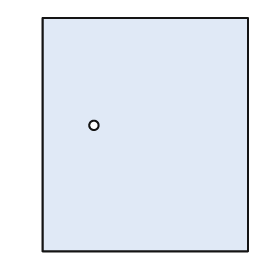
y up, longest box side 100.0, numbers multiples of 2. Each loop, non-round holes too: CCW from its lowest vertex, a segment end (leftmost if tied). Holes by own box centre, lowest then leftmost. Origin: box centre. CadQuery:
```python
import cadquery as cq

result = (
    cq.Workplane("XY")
    .moveTo(-44.0, -50.0)
    .lineTo(44.0, -50.0)
    .lineTo(44.0, 50.0)
    .lineTo(-44.0, 50.0)
    .close()
    .moveTo(-22.0, 4.0)
    .circle(2.0)
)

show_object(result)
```